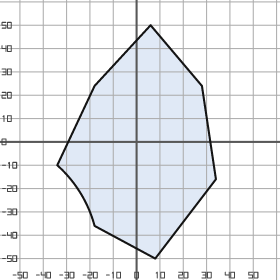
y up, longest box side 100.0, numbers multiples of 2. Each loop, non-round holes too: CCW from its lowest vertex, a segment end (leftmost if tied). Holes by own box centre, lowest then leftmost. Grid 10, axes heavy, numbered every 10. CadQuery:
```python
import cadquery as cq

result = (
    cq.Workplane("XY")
    .moveTo(8.0, -50.0)
    .lineTo(34.0, -16.0)
    .lineTo(28.0, 24.0)
    .lineTo(6.0, 50.0)
    .lineTo(-18.0, 24.0)
    .lineTo(-34.0, -10.0)
    .threePointArc((-24.0, -22.0), (-18.0, -36.0))
    .close()
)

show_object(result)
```